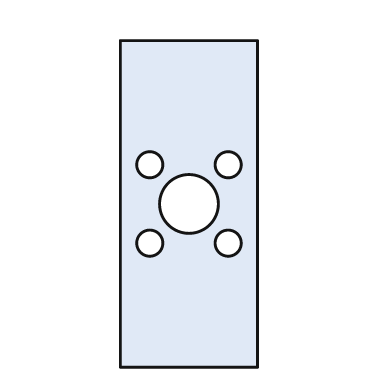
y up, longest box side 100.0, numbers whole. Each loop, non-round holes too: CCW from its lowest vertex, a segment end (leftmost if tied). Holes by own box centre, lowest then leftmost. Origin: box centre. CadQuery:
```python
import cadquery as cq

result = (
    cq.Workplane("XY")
    .moveTo(-21.0, -50.0)
    .lineTo(21.0, -50.0)
    .lineTo(21.0, 50.0)
    .lineTo(-21.0, 50.0)
    .close()
    .moveTo(-12.0, -12.0)
    .circle(4.0)
    .moveTo(12.0, -12.0)
    .circle(4.0)
    .moveTo(0.0, 0.0)
    .circle(9.0)
    .moveTo(-12.0, 12.0)
    .circle(4.0)
    .moveTo(12.0, 12.0)
    .circle(4.0)
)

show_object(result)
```